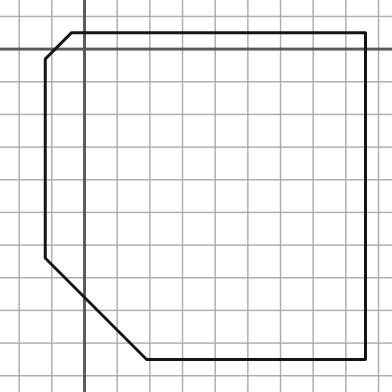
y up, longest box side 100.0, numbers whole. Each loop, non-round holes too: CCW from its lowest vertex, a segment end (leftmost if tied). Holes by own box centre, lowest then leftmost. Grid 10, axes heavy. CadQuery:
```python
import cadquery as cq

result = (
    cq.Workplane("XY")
    .moveTo(19.0, -95.0)
    .lineTo(86.0, -95.0)
    .lineTo(86.0, 5.0)
    .lineTo(-4.0, 5.0)
    .lineTo(-12.0, -3.0)
    .lineTo(-12.0, -64.0)
    .close()
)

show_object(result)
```